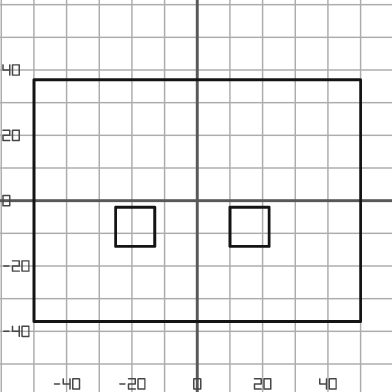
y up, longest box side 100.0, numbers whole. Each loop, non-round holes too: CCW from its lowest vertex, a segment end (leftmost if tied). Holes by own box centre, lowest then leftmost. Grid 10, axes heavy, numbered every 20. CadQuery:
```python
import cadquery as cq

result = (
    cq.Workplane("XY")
    .moveTo(-50.0, -37.0)
    .lineTo(50.0, -37.0)
    .lineTo(50.0, 37.0)
    .lineTo(-50.0, 37.0)
    .close()
    .moveTo(-25.0, -14.0)
    .lineTo(-13.0, -14.0)
    .lineTo(-13.0, -2.0)
    .lineTo(-25.0, -2.0)
    .close()
    .moveTo(10.0, -14.0)
    .lineTo(22.0, -14.0)
    .lineTo(22.0, -2.0)
    .lineTo(10.0, -2.0)
    .close()
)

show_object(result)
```